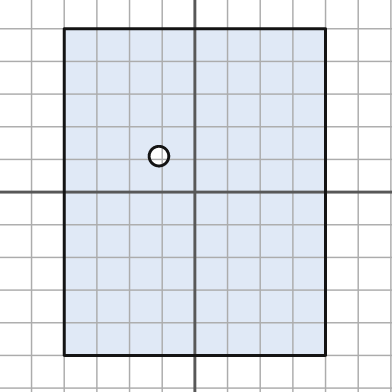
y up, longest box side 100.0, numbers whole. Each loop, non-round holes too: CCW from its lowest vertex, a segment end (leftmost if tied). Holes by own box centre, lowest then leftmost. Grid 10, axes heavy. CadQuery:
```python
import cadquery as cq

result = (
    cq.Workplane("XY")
    .moveTo(-40.0, -50.0)
    .lineTo(40.0, -50.0)
    .lineTo(40.0, 50.0)
    .lineTo(-40.0, 50.0)
    .close()
    .moveTo(-11.0, 11.0)
    .circle(3.0)
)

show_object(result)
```